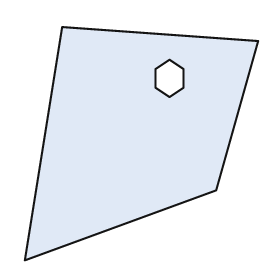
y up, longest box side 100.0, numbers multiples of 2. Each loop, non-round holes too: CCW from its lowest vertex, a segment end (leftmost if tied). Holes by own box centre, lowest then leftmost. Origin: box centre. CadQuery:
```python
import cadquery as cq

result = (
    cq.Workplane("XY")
    .moveTo(-50.0, -50.0)
    .lineTo(32.0, -20.0)
    .lineTo(50.0, 44.0)
    .lineTo(-34.0, 50.0)
    .close()
    .moveTo(12.0, 20.0)
    .lineTo(18.0, 24.0)
    .lineTo(18.0, 32.0)
    .lineTo(12.0, 36.0)
    .lineTo(6.0, 32.0)
    .lineTo(6.0, 24.0)
    .close()
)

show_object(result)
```